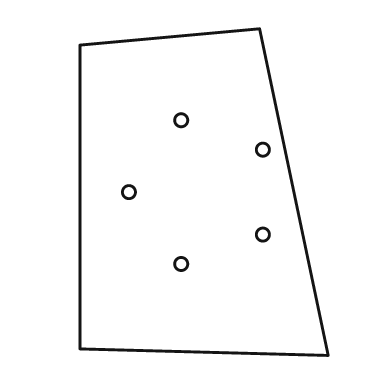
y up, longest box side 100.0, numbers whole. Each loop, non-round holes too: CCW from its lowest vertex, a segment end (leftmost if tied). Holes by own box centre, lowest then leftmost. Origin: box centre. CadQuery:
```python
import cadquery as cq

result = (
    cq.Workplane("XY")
    .moveTo(38.0, -50.0)
    .lineTo(17.0, 50.0)
    .lineTo(-38.0, 45.0)
    .lineTo(-38.0, -48.0)
    .close()
    .moveTo(-7.0, -22.0)
    .circle(2.0)
    .moveTo(18.0, -13.0)
    .circle(2.0)
    .moveTo(-23.0, 0.0)
    .circle(2.0)
    .moveTo(18.0, 13.0)
    .circle(2.0)
    .moveTo(-7.0, 22.0)
    .circle(2.0)
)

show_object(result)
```